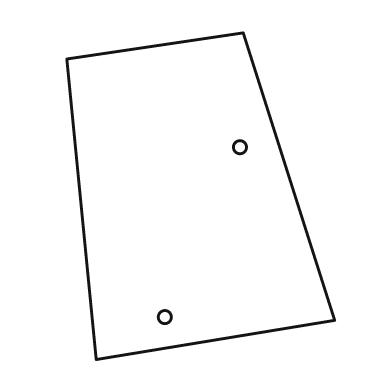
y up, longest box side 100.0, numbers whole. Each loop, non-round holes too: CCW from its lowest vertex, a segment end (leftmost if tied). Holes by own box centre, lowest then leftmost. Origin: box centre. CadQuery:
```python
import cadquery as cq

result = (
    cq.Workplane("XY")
    .moveTo(-32.0, -50.0)
    .lineTo(41.0, -38.0)
    .lineTo(13.0, 50.0)
    .lineTo(-41.0, 42.0)
    .close()
    .moveTo(-11.0, -37.0)
    .circle(2.0)
    .moveTo(12.0, 15.0)
    .circle(2.0)
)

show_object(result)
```